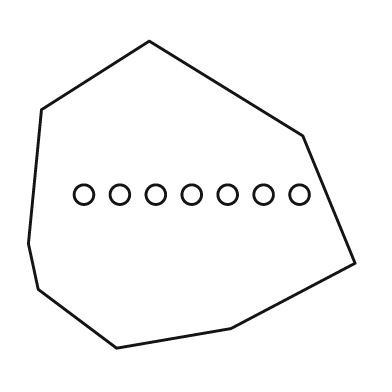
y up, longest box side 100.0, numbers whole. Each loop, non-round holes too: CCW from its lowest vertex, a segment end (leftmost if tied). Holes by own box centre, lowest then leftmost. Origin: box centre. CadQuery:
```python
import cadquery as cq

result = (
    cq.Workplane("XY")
    .moveTo(-23.0, -47.0)
    .lineTo(12.0, -41.0)
    .lineTo(50.0, -21.0)
    .lineTo(34.0, 18.0)
    .lineTo(-13.0, 47.0)
    .lineTo(-46.0, 26.0)
    .lineTo(-50.0, -15.0)
    .lineTo(-47.0, -29.0)
    .close()
    .moveTo(-33.0, 0.0)
    .circle(3.0)
    .moveTo(-22.0, 0.0)
    .circle(3.0)
    .moveTo(-11.0, 0.0)
    .circle(3.0)
    .moveTo(0.0, 0.0)
    .circle(3.0)
    .moveTo(11.0, 0.0)
    .circle(3.0)
    .moveTo(22.0, 0.0)
    .circle(3.0)
    .moveTo(33.0, 0.0)
    .circle(3.0)
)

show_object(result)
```